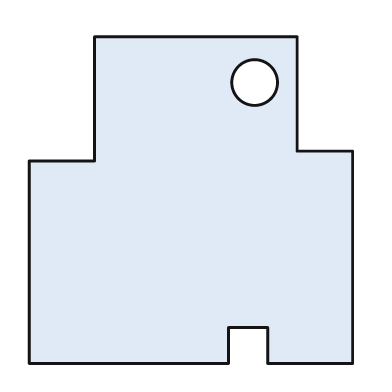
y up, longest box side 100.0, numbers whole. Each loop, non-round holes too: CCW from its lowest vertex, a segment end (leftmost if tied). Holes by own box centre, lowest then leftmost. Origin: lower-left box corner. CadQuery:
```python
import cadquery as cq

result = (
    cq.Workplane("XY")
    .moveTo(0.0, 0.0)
    .lineTo(61.0, 0.0)
    .lineTo(61.0, 11.0)
    .lineTo(73.0, 11.0)
    .lineTo(73.0, 0.0)
    .lineTo(99.0, 0.0)
    .lineTo(99.0, 65.0)
    .lineTo(82.0, 65.0)
    .lineTo(82.0, 100.0)
    .lineTo(20.0, 100.0)
    .lineTo(20.0, 62.0)
    .lineTo(0.0, 62.0)
    .close()
    .moveTo(69.0, 86.0)
    .circle(7.0)
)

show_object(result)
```